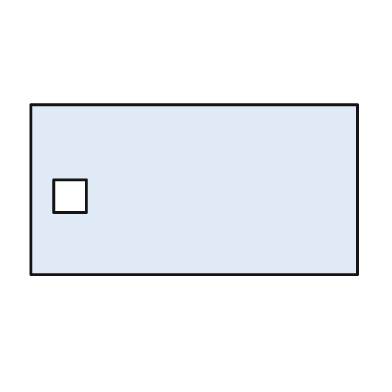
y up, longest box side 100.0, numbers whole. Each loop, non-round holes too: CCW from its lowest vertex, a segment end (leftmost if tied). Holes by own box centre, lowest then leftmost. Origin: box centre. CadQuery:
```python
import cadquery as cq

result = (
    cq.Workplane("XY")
    .moveTo(-50.0, -26.0)
    .lineTo(50.0, -26.0)
    .lineTo(50.0, 26.0)
    .lineTo(-50.0, 26.0)
    .close()
    .moveTo(-43.0, -7.0)
    .lineTo(-33.0, -7.0)
    .lineTo(-33.0, 3.0)
    .lineTo(-43.0, 3.0)
    .close()
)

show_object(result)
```